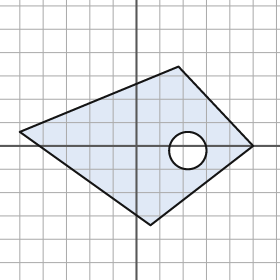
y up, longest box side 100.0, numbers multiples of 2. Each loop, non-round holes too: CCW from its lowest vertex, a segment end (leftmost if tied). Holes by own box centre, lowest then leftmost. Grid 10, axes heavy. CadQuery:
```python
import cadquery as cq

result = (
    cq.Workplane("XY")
    .moveTo(6.0, -34.0)
    .lineTo(50.0, 0.0)
    .lineTo(18.0, 34.0)
    .lineTo(-50.0, 6.0)
    .close()
    .moveTo(22.0, -2.0)
    .circle(8.0)
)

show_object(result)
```